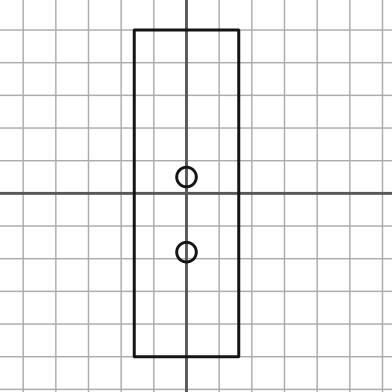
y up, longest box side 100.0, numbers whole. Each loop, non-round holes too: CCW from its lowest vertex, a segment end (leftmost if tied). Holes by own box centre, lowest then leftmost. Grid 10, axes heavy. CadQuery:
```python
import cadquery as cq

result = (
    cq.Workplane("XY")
    .moveTo(-16.0, -50.0)
    .lineTo(16.0, -50.0)
    .lineTo(16.0, 50.0)
    .lineTo(-16.0, 50.0)
    .close()
    .moveTo(0.0, -18.0)
    .circle(3.0)
    .moveTo(0.0, 5.0)
    .circle(3.0)
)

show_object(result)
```